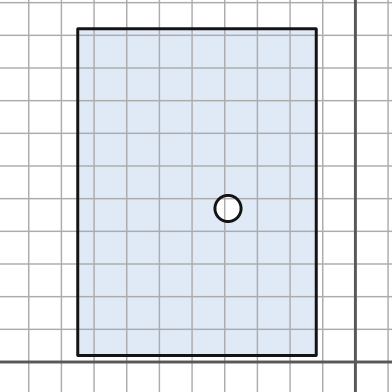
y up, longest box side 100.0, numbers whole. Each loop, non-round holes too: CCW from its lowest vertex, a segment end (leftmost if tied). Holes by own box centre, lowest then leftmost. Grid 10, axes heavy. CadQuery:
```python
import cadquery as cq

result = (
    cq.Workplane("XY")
    .moveTo(-85.0, 2.0)
    .lineTo(-12.0, 2.0)
    .lineTo(-12.0, 102.0)
    .lineTo(-85.0, 102.0)
    .close()
    .moveTo(-39.0, 47.0)
    .circle(4.0)
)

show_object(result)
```